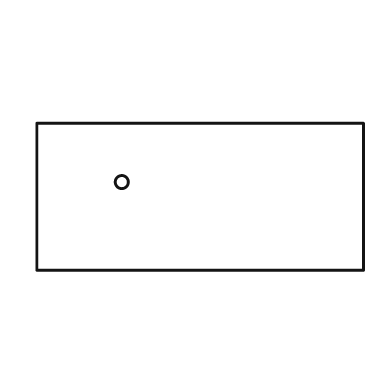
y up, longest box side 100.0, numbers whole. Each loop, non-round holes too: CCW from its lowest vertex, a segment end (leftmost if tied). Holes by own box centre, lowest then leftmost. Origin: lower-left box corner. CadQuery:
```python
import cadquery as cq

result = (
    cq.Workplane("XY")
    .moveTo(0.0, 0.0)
    .lineTo(100.0, 0.0)
    .lineTo(100.0, 45.0)
    .lineTo(0.0, 45.0)
    .close()
    .moveTo(26.0, 27.0)
    .circle(2.0)
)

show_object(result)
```